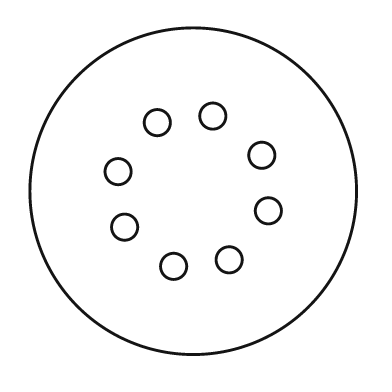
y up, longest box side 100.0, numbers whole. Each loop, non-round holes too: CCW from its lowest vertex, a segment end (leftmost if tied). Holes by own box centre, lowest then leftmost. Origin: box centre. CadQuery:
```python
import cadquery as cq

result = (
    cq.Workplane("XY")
    .moveTo(0.0, 0.0)
    .circle(50.0)
    .moveTo(-6.0, -23.0)
    .circle(4.0)
    .moveTo(11.0, -21.0)
    .circle(4.0)
    .moveTo(-21.0, -11.0)
    .circle(4.0)
    .moveTo(23.0, -6.0)
    .circle(4.0)
    .moveTo(-23.0, 6.0)
    .circle(4.0)
    .moveTo(21.0, 11.0)
    .circle(4.0)
    .moveTo(-11.0, 21.0)
    .circle(4.0)
    .moveTo(6.0, 23.0)
    .circle(4.0)
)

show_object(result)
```